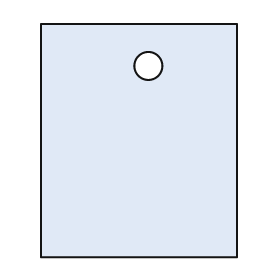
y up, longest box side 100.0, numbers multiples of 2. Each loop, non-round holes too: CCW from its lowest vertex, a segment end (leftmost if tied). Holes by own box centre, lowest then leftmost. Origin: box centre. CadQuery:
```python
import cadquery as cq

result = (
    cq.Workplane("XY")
    .moveTo(-42.0, -50.0)
    .lineTo(42.0, -50.0)
    .lineTo(42.0, 50.0)
    .lineTo(-42.0, 50.0)
    .close()
    .moveTo(4.0, 32.0)
    .circle(6.0)
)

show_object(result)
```